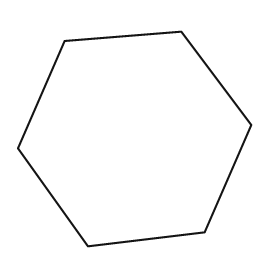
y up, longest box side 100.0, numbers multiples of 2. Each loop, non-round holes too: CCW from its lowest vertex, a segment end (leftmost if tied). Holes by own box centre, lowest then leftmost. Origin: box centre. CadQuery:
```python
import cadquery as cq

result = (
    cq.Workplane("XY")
    .moveTo(-20.0, -46.0)
    .lineTo(30.0, -40.0)
    .lineTo(50.0, 6.0)
    .lineTo(20.0, 46.0)
    .lineTo(-30.0, 42.0)
    .lineTo(-50.0, -4.0)
    .close()
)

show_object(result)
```